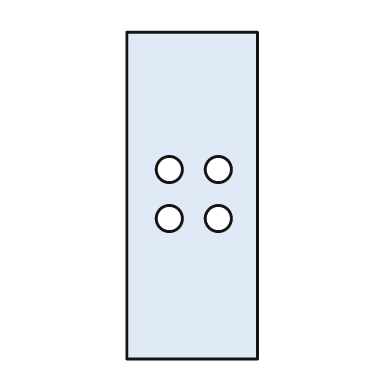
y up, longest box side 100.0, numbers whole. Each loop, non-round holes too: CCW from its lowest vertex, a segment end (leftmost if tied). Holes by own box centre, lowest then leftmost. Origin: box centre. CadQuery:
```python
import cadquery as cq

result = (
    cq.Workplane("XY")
    .moveTo(-20.0, -50.0)
    .lineTo(20.0, -50.0)
    .lineTo(20.0, 50.0)
    .lineTo(-20.0, 50.0)
    .close()
    .moveTo(-7.0, -7.0)
    .circle(4.0)
    .moveTo(8.0, -7.0)
    .circle(4.0)
    .moveTo(-7.0, 8.0)
    .circle(4.0)
    .moveTo(8.0, 8.0)
    .circle(4.0)
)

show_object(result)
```